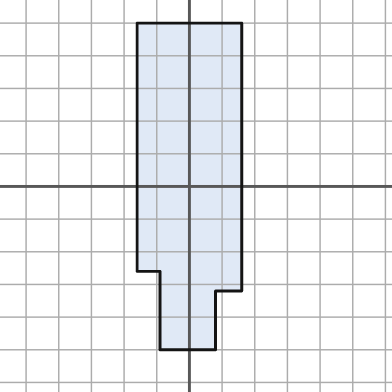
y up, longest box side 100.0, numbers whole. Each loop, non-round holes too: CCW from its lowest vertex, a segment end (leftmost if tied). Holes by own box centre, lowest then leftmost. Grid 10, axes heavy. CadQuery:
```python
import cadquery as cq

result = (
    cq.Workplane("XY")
    .moveTo(-9.0, -50.0)
    .lineTo(8.0, -50.0)
    .lineTo(8.0, -32.0)
    .lineTo(16.0, -32.0)
    .lineTo(16.0, 50.0)
    .lineTo(-16.0, 50.0)
    .lineTo(-16.0, -26.0)
    .lineTo(-9.0, -26.0)
    .close()
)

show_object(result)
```